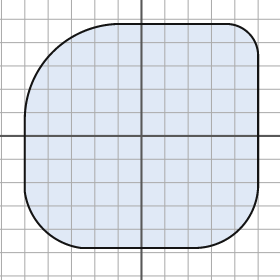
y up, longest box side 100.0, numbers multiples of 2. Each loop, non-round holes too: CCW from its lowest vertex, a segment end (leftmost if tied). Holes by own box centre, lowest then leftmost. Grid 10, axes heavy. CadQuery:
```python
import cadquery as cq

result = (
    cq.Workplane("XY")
    .moveTo(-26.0, -48.0)
    .lineTo(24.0, -48.0)
    .threePointArc((42.0, -40.0), (50.0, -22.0))
    .lineTo(50.0, 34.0)
    .threePointArc((46.0, 44.0), (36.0, 48.0))
    .lineTo(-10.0, 48.0)
    .threePointArc((-38.0, 36.0), (-50.0, 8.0))
    .lineTo(-50.0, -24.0)
    .threePointArc((-42.0, -40.0), (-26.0, -48.0))
    .close()
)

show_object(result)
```